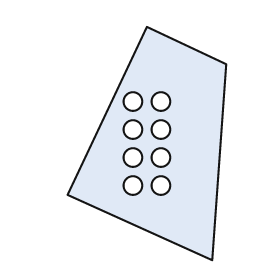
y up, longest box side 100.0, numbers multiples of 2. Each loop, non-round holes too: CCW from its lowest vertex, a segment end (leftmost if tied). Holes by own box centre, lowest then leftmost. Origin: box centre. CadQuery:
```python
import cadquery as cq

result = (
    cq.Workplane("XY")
    .moveTo(28.0, -50.0)
    .lineTo(34.0, 34.0)
    .lineTo(0.0, 50.0)
    .lineTo(-34.0, -22.0)
    .close()
    .moveTo(-6.0, -18.0)
    .circle(4.0)
    .moveTo(6.0, -18.0)
    .circle(4.0)
    .moveTo(-6.0, -6.0)
    .circle(4.0)
    .moveTo(6.0, -6.0)
    .circle(4.0)
    .moveTo(-6.0, 6.0)
    .circle(4.0)
    .moveTo(6.0, 6.0)
    .circle(4.0)
    .moveTo(-6.0, 18.0)
    .circle(4.0)
    .moveTo(6.0, 18.0)
    .circle(4.0)
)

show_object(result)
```